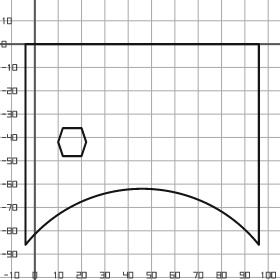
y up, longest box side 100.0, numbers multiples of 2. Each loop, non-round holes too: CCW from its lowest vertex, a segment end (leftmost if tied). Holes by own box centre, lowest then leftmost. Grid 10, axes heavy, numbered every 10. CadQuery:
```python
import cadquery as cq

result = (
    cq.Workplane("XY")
    .moveTo(-4.0, -86.0)
    .threePointArc((46.0, -62.0), (96.0, -86.0))
    .lineTo(96.0, 0.0)
    .lineTo(-4.0, 0.0)
    .close()
    .moveTo(12.0, -48.0)
    .lineTo(20.0, -48.0)
    .lineTo(22.0, -42.0)
    .lineTo(20.0, -36.0)
    .lineTo(12.0, -36.0)
    .lineTo(10.0, -42.0)
    .close()
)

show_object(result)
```